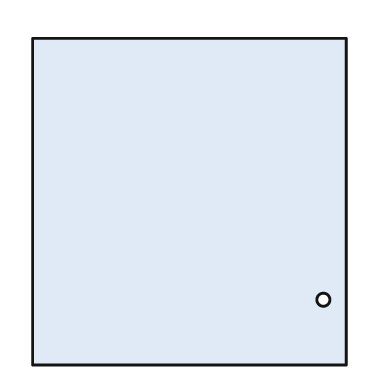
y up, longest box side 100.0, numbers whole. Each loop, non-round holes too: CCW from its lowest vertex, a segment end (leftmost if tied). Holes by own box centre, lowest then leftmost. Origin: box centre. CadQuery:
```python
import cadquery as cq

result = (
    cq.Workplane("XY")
    .moveTo(-48.0, -50.0)
    .lineTo(48.0, -50.0)
    .lineTo(48.0, 50.0)
    .lineTo(-48.0, 50.0)
    .close()
    .moveTo(41.0, -30.0)
    .circle(2.0)
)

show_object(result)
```